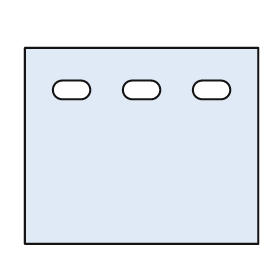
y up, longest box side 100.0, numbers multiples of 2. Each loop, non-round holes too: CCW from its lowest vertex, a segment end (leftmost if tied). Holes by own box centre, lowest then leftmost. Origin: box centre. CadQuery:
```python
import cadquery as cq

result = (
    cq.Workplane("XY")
    .moveTo(-50.0, -42.0)
    .lineTo(50.0, -42.0)
    .lineTo(50.0, 42.0)
    .lineTo(-50.0, 42.0)
    .close()
    .moveTo(-34.0, 20.0)
    .lineTo(-26.0, 20.0)
    .threePointArc((-22.0, 24.0), (-26.0, 28.0))
    .lineTo(-34.0, 28.0)
    .threePointArc((-38.0, 24.0), (-34.0, 20.0))
    .close()
    .moveTo(-4.0, 20.0)
    .lineTo(4.0, 20.0)
    .threePointArc((8.0, 24.0), (4.0, 28.0))
    .lineTo(-4.0, 28.0)
    .threePointArc((-8.0, 24.0), (-4.0, 20.0))
    .close()
    .moveTo(26.0, 20.0)
    .lineTo(34.0, 20.0)
    .threePointArc((38.0, 24.0), (34.0, 28.0))
    .lineTo(26.0, 28.0)
    .threePointArc((22.0, 24.0), (26.0, 20.0))
    .close()
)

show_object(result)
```